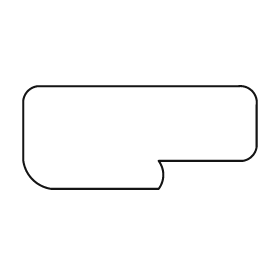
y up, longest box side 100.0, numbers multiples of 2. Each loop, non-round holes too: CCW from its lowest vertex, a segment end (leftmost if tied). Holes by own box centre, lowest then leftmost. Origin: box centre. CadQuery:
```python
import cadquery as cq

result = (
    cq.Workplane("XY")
    .moveTo(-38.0, -22.0)
    .lineTo(8.0, -22.0)
    .threePointArc((10.0, -16.0), (8.0, -10.0))
    .lineTo(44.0, -10.0)
    .threePointArc((48.0, -8.0), (50.0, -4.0))
    .lineTo(50.0, 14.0)
    .threePointArc((48.0, 20.0), (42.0, 22.0))
    .lineTo(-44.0, 22.0)
    .threePointArc((-48.0, 20.0), (-50.0, 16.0))
    .lineTo(-50.0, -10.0)
    .threePointArc((-46.0, -18.0), (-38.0, -22.0))
    .close()
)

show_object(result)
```